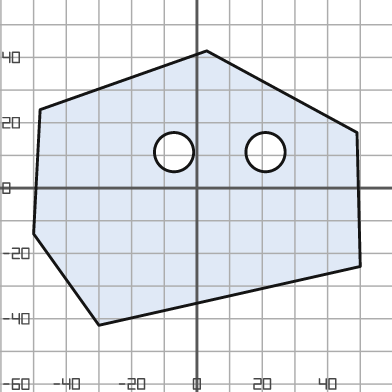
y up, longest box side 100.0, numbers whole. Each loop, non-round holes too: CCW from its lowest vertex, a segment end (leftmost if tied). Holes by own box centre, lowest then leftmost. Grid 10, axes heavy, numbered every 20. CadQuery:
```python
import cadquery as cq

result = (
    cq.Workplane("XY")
    .moveTo(-30.0, -42.0)
    .lineTo(50.0, -24.0)
    .lineTo(49.0, 17.0)
    .lineTo(3.0, 42.0)
    .lineTo(-48.0, 24.0)
    .lineTo(-50.0, -14.0)
    .close()
    .moveTo(-7.0, 11.0)
    .circle(6.0)
    .moveTo(21.0, 11.0)
    .circle(6.0)
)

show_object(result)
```